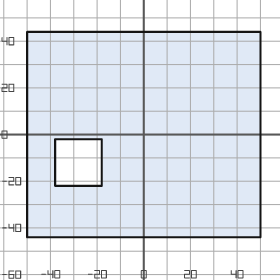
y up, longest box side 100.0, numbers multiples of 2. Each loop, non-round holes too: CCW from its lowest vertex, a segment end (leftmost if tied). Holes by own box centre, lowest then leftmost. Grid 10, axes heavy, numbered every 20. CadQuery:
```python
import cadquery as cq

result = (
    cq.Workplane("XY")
    .moveTo(-50.0, -44.0)
    .lineTo(50.0, -44.0)
    .lineTo(50.0, 44.0)
    .lineTo(-50.0, 44.0)
    .close()
    .moveTo(-38.0, -22.0)
    .lineTo(-18.0, -22.0)
    .lineTo(-18.0, -2.0)
    .lineTo(-38.0, -2.0)
    .close()
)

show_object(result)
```